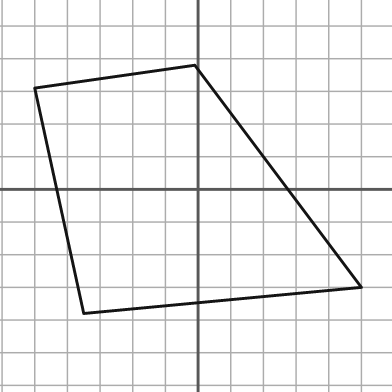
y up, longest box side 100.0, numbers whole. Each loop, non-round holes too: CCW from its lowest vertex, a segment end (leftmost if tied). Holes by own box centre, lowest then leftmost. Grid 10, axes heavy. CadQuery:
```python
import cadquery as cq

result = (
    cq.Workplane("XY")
    .moveTo(-35.0, -38.0)
    .lineTo(50.0, -30.0)
    .lineTo(-1.0, 38.0)
    .lineTo(-50.0, 31.0)
    .close()
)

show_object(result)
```